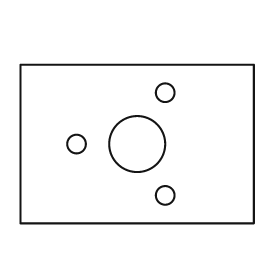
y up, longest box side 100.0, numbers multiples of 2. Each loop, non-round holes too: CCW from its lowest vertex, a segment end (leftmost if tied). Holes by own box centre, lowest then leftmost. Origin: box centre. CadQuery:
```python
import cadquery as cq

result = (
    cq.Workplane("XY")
    .moveTo(-50.0, -34.0)
    .lineTo(50.0, -34.0)
    .lineTo(50.0, 34.0)
    .lineTo(-50.0, 34.0)
    .close()
    .moveTo(12.0, -22.0)
    .circle(4.0)
    .moveTo(-26.0, 0.0)
    .circle(4.0)
    .moveTo(0.0, 0.0)
    .circle(12.0)
    .moveTo(12.0, 22.0)
    .circle(4.0)
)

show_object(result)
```